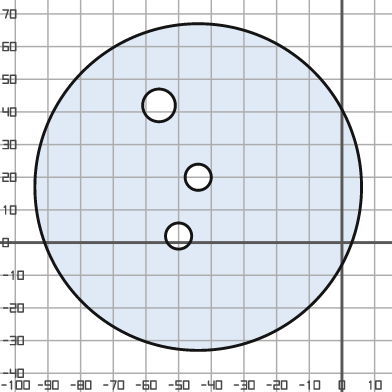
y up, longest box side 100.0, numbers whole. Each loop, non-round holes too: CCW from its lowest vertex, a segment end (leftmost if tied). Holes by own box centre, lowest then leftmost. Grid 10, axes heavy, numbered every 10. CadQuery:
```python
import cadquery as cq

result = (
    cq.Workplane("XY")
    .moveTo(-44.0, 17.0)
    .circle(50.0)
    .moveTo(-50.0, 2.0)
    .circle(4.0)
    .moveTo(-44.0, 20.0)
    .circle(4.0)
    .moveTo(-56.0, 42.0)
    .circle(5.0)
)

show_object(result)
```